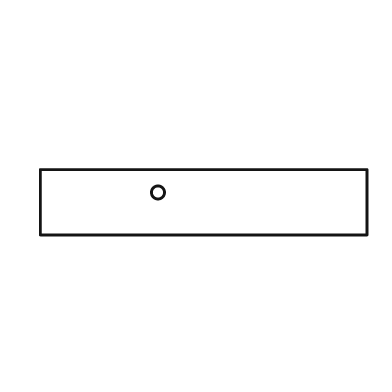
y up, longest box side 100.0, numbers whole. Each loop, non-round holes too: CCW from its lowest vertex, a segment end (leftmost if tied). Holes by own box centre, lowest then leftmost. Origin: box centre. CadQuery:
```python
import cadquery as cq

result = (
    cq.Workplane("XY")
    .moveTo(-50.0, -10.0)
    .lineTo(50.0, -10.0)
    .lineTo(50.0, 10.0)
    .lineTo(-50.0, 10.0)
    .close()
    .moveTo(-14.0, 3.0)
    .circle(2.0)
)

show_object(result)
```